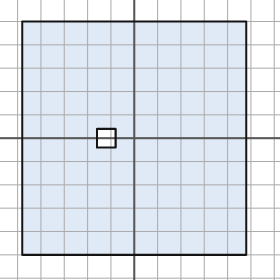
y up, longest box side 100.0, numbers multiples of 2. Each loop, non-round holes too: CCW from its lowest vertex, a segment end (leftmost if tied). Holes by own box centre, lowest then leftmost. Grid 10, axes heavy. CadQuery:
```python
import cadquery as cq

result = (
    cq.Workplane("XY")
    .moveTo(-48.0, -50.0)
    .lineTo(48.0, -50.0)
    .lineTo(48.0, 50.0)
    .lineTo(-48.0, 50.0)
    .close()
    .moveTo(-16.0, -4.0)
    .lineTo(-8.0, -4.0)
    .lineTo(-8.0, 4.0)
    .lineTo(-16.0, 4.0)
    .close()
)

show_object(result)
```